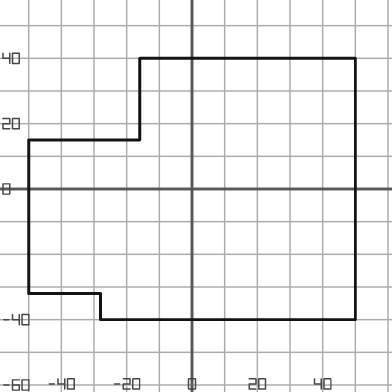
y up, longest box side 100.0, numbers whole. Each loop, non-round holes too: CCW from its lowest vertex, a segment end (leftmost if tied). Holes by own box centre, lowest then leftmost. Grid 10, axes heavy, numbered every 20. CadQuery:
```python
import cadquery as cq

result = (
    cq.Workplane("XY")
    .moveTo(-28.0, -40.0)
    .lineTo(50.0, -40.0)
    .lineTo(50.0, 40.0)
    .lineTo(-16.0, 40.0)
    .lineTo(-16.0, 15.0)
    .lineTo(-50.0, 15.0)
    .lineTo(-50.0, -32.0)
    .lineTo(-28.0, -32.0)
    .close()
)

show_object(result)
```